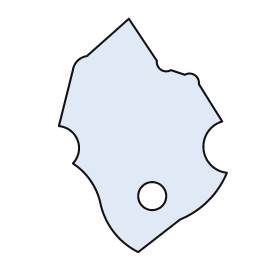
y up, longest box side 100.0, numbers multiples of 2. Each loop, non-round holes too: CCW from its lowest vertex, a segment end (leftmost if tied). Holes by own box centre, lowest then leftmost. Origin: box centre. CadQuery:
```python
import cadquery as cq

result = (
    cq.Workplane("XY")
    .moveTo(-2.0, -50.0)
    .lineTo(16.0, -36.0)
    .threePointArc((28.0, -28.0), (36.0, -16.0))
    .threePointArc((26.0, -6.0), (34.0, 6.0))
    .lineTo(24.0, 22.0)
    .threePointArc((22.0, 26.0), (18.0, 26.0))
    .lineTo(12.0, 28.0)
    .threePointArc((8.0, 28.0), (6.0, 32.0))
    .lineTo(-6.0, 50.0)
    .lineTo(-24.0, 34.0)
    .threePointArc((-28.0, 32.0), (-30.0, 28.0))
    .lineTo(-36.0, 4.0)
    .threePointArc((-28.0, -2.0), (-30.0, -12.0))
    .threePointArc((-22.0, -20.0), (-18.0, -30.0))
    .threePointArc((-12.0, -42.0), (-2.0, -50.0))
    .close()
    .moveTo(4.0, -26.0)
    .circle(6.0)
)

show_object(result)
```